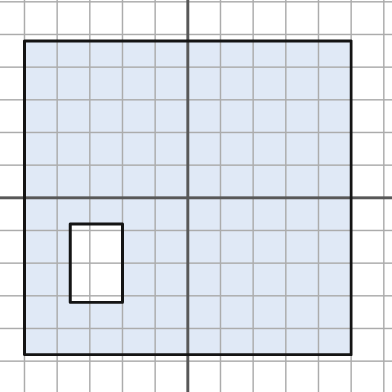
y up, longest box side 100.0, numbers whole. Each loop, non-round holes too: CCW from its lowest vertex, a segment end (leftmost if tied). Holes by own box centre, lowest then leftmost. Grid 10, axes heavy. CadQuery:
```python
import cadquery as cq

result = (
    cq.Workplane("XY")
    .moveTo(-50.0, -48.0)
    .lineTo(50.0, -48.0)
    .lineTo(50.0, 48.0)
    .lineTo(-50.0, 48.0)
    .close()
    .moveTo(-36.0, -32.0)
    .lineTo(-20.0, -32.0)
    .lineTo(-20.0, -8.0)
    .lineTo(-36.0, -8.0)
    .close()
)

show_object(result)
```